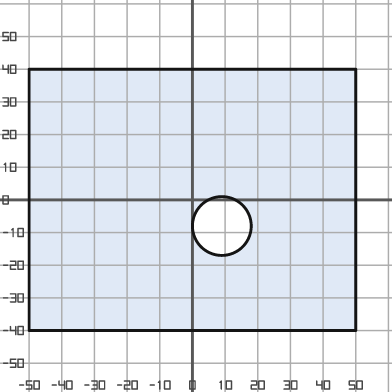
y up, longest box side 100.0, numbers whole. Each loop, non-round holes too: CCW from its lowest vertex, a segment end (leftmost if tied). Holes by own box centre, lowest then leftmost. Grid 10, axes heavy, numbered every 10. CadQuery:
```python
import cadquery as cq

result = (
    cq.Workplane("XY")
    .moveTo(-50.0, -40.0)
    .lineTo(50.0, -40.0)
    .lineTo(50.0, 40.0)
    .lineTo(-50.0, 40.0)
    .close()
    .moveTo(9.0, -8.0)
    .circle(9.0)
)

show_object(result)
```